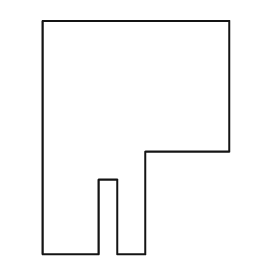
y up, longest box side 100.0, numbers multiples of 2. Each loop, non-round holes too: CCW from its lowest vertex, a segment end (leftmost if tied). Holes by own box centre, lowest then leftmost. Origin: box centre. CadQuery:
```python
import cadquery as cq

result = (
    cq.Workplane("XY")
    .moveTo(-40.0, -50.0)
    .lineTo(-16.0, -50.0)
    .lineTo(-16.0, -18.0)
    .lineTo(-8.0, -18.0)
    .lineTo(-8.0, -50.0)
    .lineTo(4.0, -50.0)
    .lineTo(4.0, -6.0)
    .lineTo(40.0, -6.0)
    .lineTo(40.0, 50.0)
    .lineTo(-40.0, 50.0)
    .close()
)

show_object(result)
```